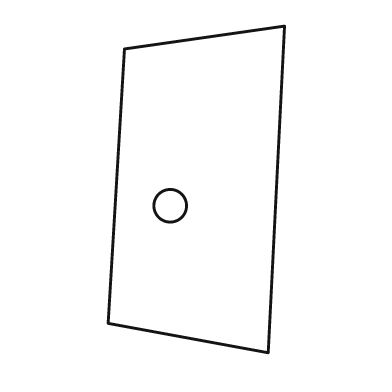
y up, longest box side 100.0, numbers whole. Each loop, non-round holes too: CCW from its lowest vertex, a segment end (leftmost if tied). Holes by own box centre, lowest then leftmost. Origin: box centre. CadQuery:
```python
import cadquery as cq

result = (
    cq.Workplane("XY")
    .moveTo(22.0, -50.0)
    .lineTo(27.0, 50.0)
    .lineTo(-22.0, 43.0)
    .lineTo(-27.0, -41.0)
    .close()
    .moveTo(-8.0, -5.0)
    .circle(5.0)
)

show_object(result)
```